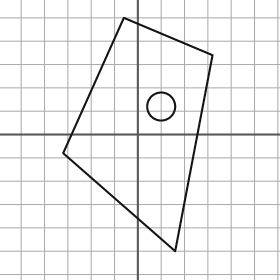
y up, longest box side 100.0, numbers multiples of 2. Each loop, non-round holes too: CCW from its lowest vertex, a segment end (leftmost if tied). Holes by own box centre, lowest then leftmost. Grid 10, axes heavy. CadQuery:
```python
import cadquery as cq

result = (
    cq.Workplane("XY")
    .moveTo(16.0, -50.0)
    .lineTo(32.0, 34.0)
    .lineTo(-6.0, 50.0)
    .lineTo(-32.0, -8.0)
    .close()
    .moveTo(10.0, 12.0)
    .circle(6.0)
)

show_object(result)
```